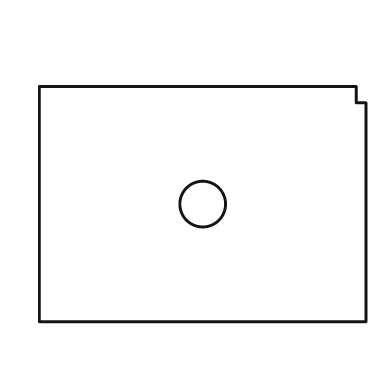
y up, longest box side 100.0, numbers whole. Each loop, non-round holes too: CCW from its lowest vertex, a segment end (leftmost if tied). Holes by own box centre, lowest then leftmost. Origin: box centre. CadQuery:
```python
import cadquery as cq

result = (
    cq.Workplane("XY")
    .moveTo(-50.0, -36.0)
    .lineTo(50.0, -36.0)
    .lineTo(50.0, 31.0)
    .lineTo(47.0, 31.0)
    .lineTo(47.0, 36.0)
    .lineTo(-50.0, 36.0)
    .close()
    .moveTo(0.0, 0.0)
    .circle(7.0)
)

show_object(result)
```